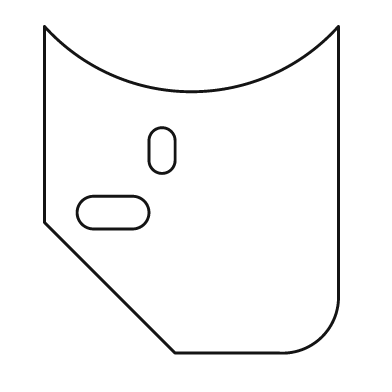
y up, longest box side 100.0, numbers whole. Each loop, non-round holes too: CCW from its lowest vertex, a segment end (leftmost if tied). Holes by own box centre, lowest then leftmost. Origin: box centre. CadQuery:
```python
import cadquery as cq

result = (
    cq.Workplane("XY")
    .moveTo(-5.0, -50.0)
    .lineTo(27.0, -50.0)
    .threePointArc((40.0, -45.0), (45.0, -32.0))
    .lineTo(45.0, 50.0)
    .threePointArc((0.0, 30.0), (-45.0, 50.0))
    .lineTo(-45.0, -10.0)
    .close()
    .moveTo(-30.0, -12.0)
    .lineTo(-18.0, -12.0)
    .threePointArc((-13.0, -7.0), (-18.0, -2.0))
    .lineTo(-30.0, -2.0)
    .threePointArc((-35.0, -7.0), (-30.0, -12.0))
    .close()
    .moveTo(-13.0, 9.0)
    .threePointArc((-9.0, 5.0), (-5.0, 9.0))
    .lineTo(-5.0, 15.0)
    .threePointArc((-9.0, 19.0), (-13.0, 15.0))
    .close()
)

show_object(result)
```